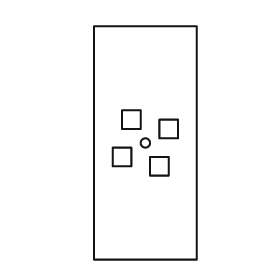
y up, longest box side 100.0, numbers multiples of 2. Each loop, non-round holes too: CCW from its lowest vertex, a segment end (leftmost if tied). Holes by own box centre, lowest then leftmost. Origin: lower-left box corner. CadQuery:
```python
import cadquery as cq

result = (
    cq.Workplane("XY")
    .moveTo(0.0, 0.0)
    .lineTo(44.0, 0.0)
    .lineTo(44.0, 100.0)
    .lineTo(0.0, 100.0)
    .close()
    .moveTo(24.0, 36.0)
    .lineTo(32.0, 36.0)
    .lineTo(32.0, 44.0)
    .lineTo(24.0, 44.0)
    .close()
    .moveTo(8.0, 40.0)
    .lineTo(16.0, 40.0)
    .lineTo(16.0, 48.0)
    .lineTo(8.0, 48.0)
    .close()
    .moveTo(22.0, 50.0)
    .circle(2.0)
    .moveTo(28.0, 52.0)
    .lineTo(36.0, 52.0)
    .lineTo(36.0, 60.0)
    .lineTo(28.0, 60.0)
    .close()
    .moveTo(12.0, 56.0)
    .lineTo(20.0, 56.0)
    .lineTo(20.0, 64.0)
    .lineTo(12.0, 64.0)
    .close()
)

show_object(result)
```